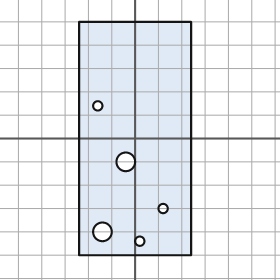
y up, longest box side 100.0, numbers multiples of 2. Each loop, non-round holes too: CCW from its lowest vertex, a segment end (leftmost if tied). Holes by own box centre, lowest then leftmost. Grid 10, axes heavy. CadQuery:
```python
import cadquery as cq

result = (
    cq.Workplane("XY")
    .moveTo(-24.0, -50.0)
    .lineTo(24.0, -50.0)
    .lineTo(24.0, 50.0)
    .lineTo(-24.0, 50.0)
    .close()
    .moveTo(2.0, -44.0)
    .circle(2.0)
    .moveTo(-14.0, -40.0)
    .circle(4.0)
    .moveTo(12.0, -30.0)
    .circle(2.0)
    .moveTo(-4.0, -10.0)
    .circle(4.0)
    .moveTo(-16.0, 14.0)
    .circle(2.0)
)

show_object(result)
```